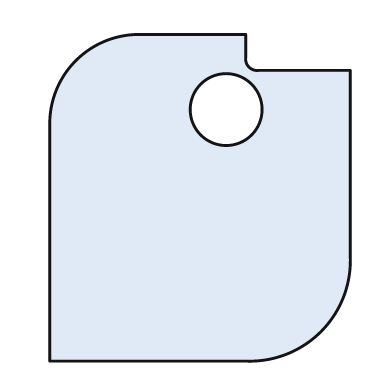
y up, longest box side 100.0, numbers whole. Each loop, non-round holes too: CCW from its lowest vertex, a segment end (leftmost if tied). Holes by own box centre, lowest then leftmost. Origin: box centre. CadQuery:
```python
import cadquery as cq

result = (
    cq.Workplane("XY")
    .moveTo(-46.0, -50.0)
    .lineTo(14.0, -50.0)
    .threePointArc((37.0, -41.0), (46.0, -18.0))
    .lineTo(46.0, 39.0)
    .lineTo(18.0, 39.0)
    .threePointArc((15.0, 40.0), (14.0, 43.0))
    .lineTo(14.0, 50.0)
    .lineTo(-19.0, 50.0)
    .threePointArc((-38.0, 42.0), (-46.0, 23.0))
    .close()
    .moveTo(8.0, 27.0)
    .circle(11.0)
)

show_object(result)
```